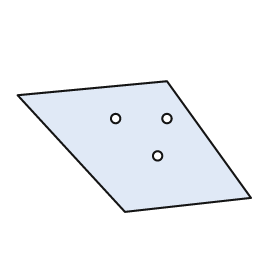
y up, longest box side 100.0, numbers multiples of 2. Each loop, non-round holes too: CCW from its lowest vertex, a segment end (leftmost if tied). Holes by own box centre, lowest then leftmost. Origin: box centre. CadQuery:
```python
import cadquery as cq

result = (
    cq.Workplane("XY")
    .moveTo(-4.0, -28.0)
    .lineTo(50.0, -22.0)
    .lineTo(14.0, 28.0)
    .lineTo(-50.0, 22.0)
    .close()
    .moveTo(10.0, -4.0)
    .circle(2.0)
    .moveTo(-8.0, 12.0)
    .circle(2.0)
    .moveTo(14.0, 12.0)
    .circle(2.0)
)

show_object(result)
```